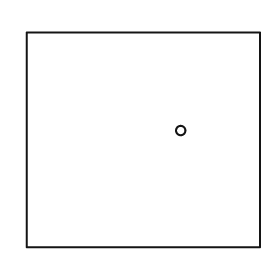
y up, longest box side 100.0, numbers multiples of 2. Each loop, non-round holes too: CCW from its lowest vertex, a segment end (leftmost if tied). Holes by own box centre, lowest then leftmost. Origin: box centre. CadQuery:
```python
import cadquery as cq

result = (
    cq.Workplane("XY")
    .moveTo(-50.0, -46.0)
    .lineTo(50.0, -46.0)
    .lineTo(50.0, 46.0)
    .lineTo(-50.0, 46.0)
    .close()
    .moveTo(16.0, 4.0)
    .circle(2.0)
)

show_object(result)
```